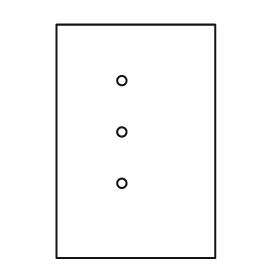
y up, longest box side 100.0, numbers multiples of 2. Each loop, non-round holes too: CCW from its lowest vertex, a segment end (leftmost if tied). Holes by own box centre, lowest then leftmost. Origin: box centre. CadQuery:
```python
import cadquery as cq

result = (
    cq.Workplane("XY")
    .moveTo(-34.0, -50.0)
    .lineTo(34.0, -50.0)
    .lineTo(34.0, 50.0)
    .lineTo(-34.0, 50.0)
    .close()
    .moveTo(-6.0, -18.0)
    .circle(2.0)
    .moveTo(-6.0, 4.0)
    .circle(2.0)
    .moveTo(-6.0, 26.0)
    .circle(2.0)
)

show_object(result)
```